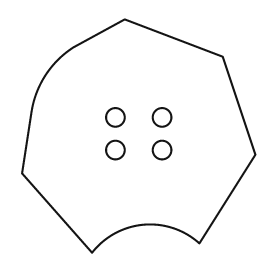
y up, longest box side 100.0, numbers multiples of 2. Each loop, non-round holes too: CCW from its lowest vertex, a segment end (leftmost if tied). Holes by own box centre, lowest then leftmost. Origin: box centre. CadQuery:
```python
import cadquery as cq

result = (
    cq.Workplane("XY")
    .moveTo(-20.0, -50.0)
    .threePointArc((2.0, -38.0), (26.0, -46.0))
    .lineTo(50.0, -8.0)
    .lineTo(36.0, 34.0)
    .lineTo(-6.0, 50.0)
    .lineTo(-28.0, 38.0)
    .threePointArc((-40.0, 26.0), (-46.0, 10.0))
    .lineTo(-50.0, -16.0)
    .close()
    .moveTo(-10.0, -6.0)
    .circle(4.0)
    .moveTo(10.0, -6.0)
    .circle(4.0)
    .moveTo(-10.0, 8.0)
    .circle(4.0)
    .moveTo(10.0, 8.0)
    .circle(4.0)
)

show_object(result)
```